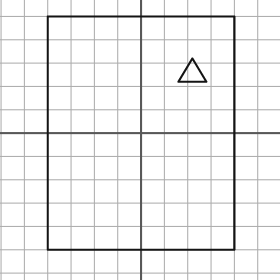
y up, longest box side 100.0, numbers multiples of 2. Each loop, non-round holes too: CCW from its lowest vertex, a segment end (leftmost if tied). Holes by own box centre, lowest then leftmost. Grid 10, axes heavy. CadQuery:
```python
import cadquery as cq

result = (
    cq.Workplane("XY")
    .moveTo(-40.0, -50.0)
    .lineTo(40.0, -50.0)
    .lineTo(40.0, 50.0)
    .lineTo(-40.0, 50.0)
    .close()
    .moveTo(16.0, 22.0)
    .lineTo(28.0, 22.0)
    .lineTo(22.0, 32.0)
    .close()
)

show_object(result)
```